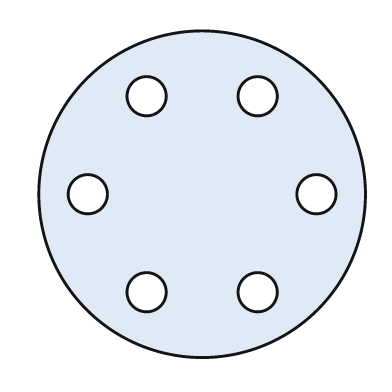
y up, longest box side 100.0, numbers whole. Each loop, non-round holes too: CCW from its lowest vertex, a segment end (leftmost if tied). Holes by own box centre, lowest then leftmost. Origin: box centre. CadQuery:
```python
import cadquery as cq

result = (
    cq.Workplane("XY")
    .moveTo(0.0, 0.0)
    .circle(50.0)
    .moveTo(-17.0, -30.0)
    .circle(6.0)
    .moveTo(17.0, -30.0)
    .circle(6.0)
    .moveTo(-35.0, 0.0)
    .circle(6.0)
    .moveTo(35.0, 0.0)
    .circle(6.0)
    .moveTo(-17.0, 30.0)
    .circle(6.0)
    .moveTo(17.0, 30.0)
    .circle(6.0)
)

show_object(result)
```